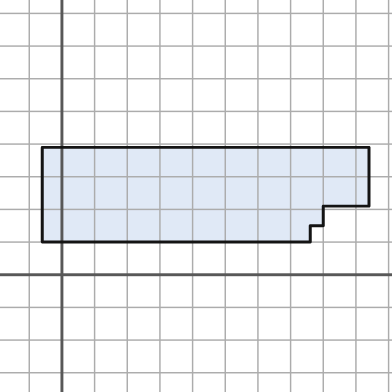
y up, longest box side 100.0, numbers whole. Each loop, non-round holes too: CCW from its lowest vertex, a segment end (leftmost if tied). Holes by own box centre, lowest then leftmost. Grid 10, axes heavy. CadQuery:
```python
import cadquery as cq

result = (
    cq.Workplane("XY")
    .moveTo(-6.0, 10.0)
    .lineTo(76.0, 10.0)
    .lineTo(76.0, 15.0)
    .lineTo(80.0, 15.0)
    .lineTo(80.0, 21.0)
    .lineTo(94.0, 21.0)
    .lineTo(94.0, 39.0)
    .lineTo(-6.0, 39.0)
    .close()
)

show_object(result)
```